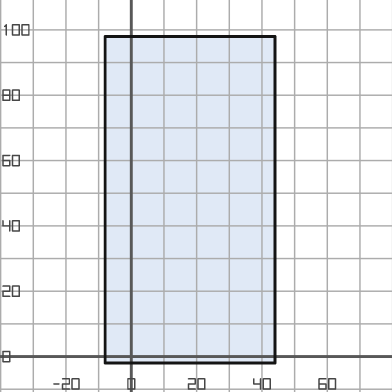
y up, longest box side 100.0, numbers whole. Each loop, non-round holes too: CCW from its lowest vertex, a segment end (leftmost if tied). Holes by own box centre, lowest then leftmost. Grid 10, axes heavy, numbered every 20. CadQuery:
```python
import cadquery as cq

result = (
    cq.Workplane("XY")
    .moveTo(-8.0, -2.0)
    .lineTo(44.0, -2.0)
    .lineTo(44.0, 98.0)
    .lineTo(-8.0, 98.0)
    .close()
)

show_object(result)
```